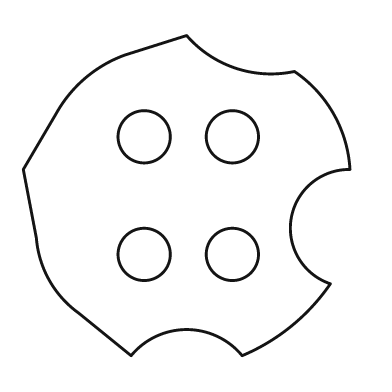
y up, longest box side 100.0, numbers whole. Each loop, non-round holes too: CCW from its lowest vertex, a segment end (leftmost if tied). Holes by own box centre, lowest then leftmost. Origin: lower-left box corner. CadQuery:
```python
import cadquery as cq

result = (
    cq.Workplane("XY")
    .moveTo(33.0, 0.0)
    .threePointArc((50.0, 8.0), (67.0, 0.0))
    .threePointArc((82.0, 9.0), (94.0, 22.0))
    .threePointArc((82.0, 42.0), (100.0, 57.0))
    .threePointArc((95.0, 74.0), (83.0, 87.0))
    .threePointArc((65.0, 88.0), (50.0, 98.0))
    .lineTo(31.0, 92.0)
    .threePointArc((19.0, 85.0), (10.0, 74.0))
    .lineTo(0.0, 57.0)
    .lineTo(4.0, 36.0)
    .threePointArc((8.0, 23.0), (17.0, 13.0))
    .close()
    .moveTo(37.0, 31.0)
    .circle(8.0)
    .moveTo(64.0, 31.0)
    .circle(8.0)
    .moveTo(37.0, 67.0)
    .circle(8.0)
    .moveTo(64.0, 67.0)
    .circle(8.0)
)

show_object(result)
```